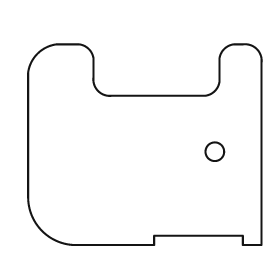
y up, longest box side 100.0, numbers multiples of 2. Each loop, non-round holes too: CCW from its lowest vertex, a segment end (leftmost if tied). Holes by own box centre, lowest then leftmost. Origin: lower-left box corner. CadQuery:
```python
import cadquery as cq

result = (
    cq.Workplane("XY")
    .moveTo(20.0, 0.0)
    .lineTo(54.0, 0.0)
    .lineTo(54.0, 4.0)
    .lineTo(92.0, 4.0)
    .lineTo(92.0, 0.0)
    .lineTo(100.0, 0.0)
    .lineTo(100.0, 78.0)
    .threePointArc((98.0, 84.0), (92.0, 86.0))
    .lineTo(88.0, 86.0)
    .threePointArc((84.0, 84.0), (82.0, 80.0))
    .lineTo(82.0, 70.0)
    .threePointArc((80.0, 66.0), (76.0, 64.0))
    .lineTo(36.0, 64.0)
    .threePointArc((30.0, 66.0), (28.0, 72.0))
    .lineTo(28.0, 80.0)
    .threePointArc((26.0, 84.0), (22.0, 86.0))
    .lineTo(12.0, 86.0)
    .threePointArc((4.0, 82.0), (0.0, 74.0))
    .lineTo(0.0, 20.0)
    .threePointArc((6.0, 6.0), (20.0, 0.0))
    .close()
    .moveTo(80.0, 40.0)
    .circle(4.0)
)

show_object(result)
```